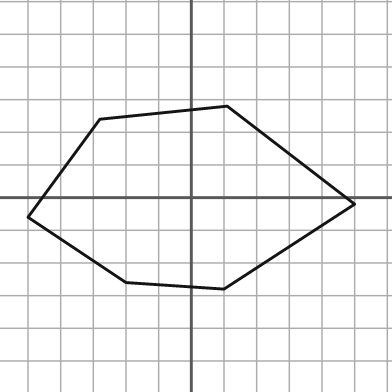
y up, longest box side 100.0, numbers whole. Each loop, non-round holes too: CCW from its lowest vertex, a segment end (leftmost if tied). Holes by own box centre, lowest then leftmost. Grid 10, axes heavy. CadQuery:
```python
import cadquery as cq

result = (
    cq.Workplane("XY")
    .moveTo(10.0, -28.0)
    .lineTo(50.0, -2.0)
    .lineTo(11.0, 28.0)
    .lineTo(-28.0, 24.0)
    .lineTo(-50.0, -6.0)
    .lineTo(-20.0, -26.0)
    .close()
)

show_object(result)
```